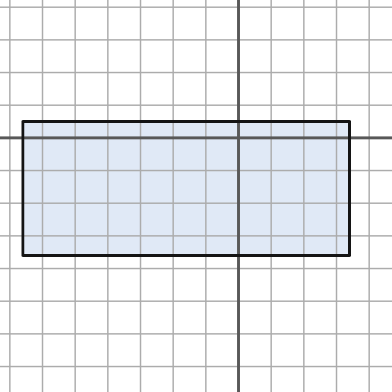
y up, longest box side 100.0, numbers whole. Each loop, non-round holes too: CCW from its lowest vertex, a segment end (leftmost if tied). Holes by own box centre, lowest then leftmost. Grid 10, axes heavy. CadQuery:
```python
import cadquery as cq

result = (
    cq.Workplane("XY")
    .moveTo(-66.0, -36.0)
    .lineTo(34.0, -36.0)
    .lineTo(34.0, 5.0)
    .lineTo(-66.0, 5.0)
    .close()
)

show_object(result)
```